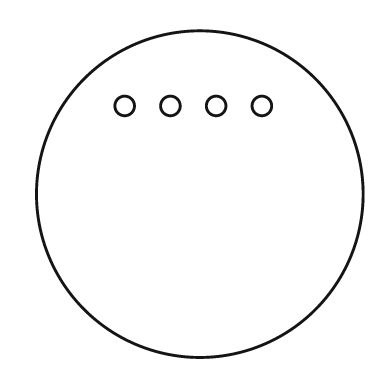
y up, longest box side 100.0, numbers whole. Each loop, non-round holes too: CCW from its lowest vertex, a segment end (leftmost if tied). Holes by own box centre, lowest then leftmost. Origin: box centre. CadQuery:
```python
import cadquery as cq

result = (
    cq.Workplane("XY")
    .moveTo(0.0, 0.0)
    .circle(50.0)
    .moveTo(-23.0, 27.0)
    .circle(3.0)
    .moveTo(-9.0, 27.0)
    .circle(3.0)
    .moveTo(5.0, 27.0)
    .circle(3.0)
    .moveTo(19.0, 27.0)
    .circle(3.0)
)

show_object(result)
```